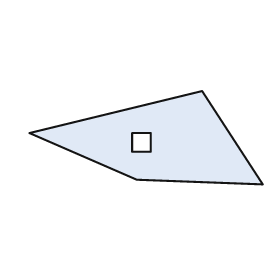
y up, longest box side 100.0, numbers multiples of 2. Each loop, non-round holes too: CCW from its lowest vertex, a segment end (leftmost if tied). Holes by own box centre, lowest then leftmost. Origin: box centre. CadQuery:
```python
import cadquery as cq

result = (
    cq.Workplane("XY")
    .moveTo(50.0, -20.0)
    .lineTo(24.0, 20.0)
    .lineTo(-50.0, 2.0)
    .lineTo(-4.0, -18.0)
    .close()
    .moveTo(-6.0, -6.0)
    .lineTo(2.0, -6.0)
    .lineTo(2.0, 2.0)
    .lineTo(-6.0, 2.0)
    .close()
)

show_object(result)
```